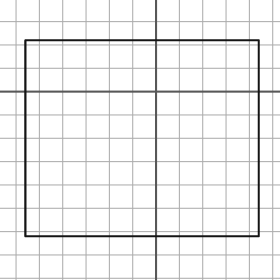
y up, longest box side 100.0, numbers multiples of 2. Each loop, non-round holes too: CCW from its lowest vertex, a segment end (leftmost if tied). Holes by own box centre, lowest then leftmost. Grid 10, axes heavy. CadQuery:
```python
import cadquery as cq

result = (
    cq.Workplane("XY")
    .moveTo(-56.0, -62.0)
    .lineTo(44.0, -62.0)
    .lineTo(44.0, 22.0)
    .lineTo(-56.0, 22.0)
    .close()
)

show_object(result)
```